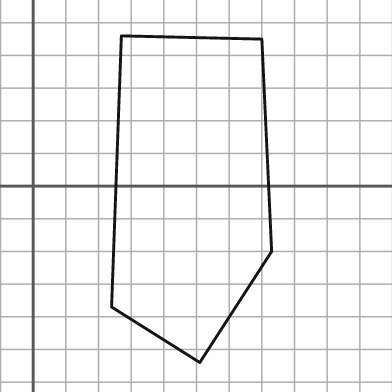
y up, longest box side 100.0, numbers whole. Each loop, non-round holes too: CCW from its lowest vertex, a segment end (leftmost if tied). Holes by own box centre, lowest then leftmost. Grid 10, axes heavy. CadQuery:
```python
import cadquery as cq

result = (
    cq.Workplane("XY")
    .moveTo(51.0, -54.0)
    .lineTo(73.0, -20.0)
    .lineTo(70.0, 45.0)
    .lineTo(27.0, 46.0)
    .lineTo(24.0, -37.0)
    .close()
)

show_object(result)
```